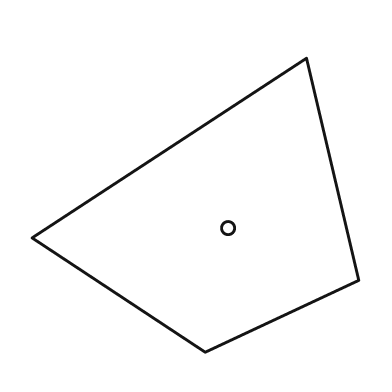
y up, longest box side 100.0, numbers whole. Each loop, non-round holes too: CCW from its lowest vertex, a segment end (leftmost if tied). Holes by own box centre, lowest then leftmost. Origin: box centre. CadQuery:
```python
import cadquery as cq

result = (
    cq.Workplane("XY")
    .moveTo(3.0, -45.0)
    .lineTo(50.0, -23.0)
    .lineTo(34.0, 45.0)
    .lineTo(-50.0, -10.0)
    .close()
    .moveTo(10.0, -7.0)
    .circle(2.0)
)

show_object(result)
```